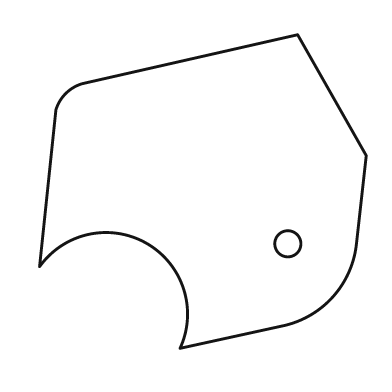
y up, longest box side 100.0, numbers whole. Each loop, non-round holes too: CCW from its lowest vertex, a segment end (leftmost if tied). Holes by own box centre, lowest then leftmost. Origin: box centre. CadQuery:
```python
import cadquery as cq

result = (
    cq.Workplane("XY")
    .moveTo(-7.0, -48.0)
    .lineTo(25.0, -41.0)
    .threePointArc((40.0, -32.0), (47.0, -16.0))
    .lineTo(50.0, 11.0)
    .lineTo(29.0, 48.0)
    .lineTo(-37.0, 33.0)
    .threePointArc((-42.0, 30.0), (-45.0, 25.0))
    .lineTo(-50.0, -23.0)
    .threePointArc((-17.0, -16.0), (-7.0, -48.0))
    .close()
    .moveTo(26.0, -16.0)
    .circle(4.0)
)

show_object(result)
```